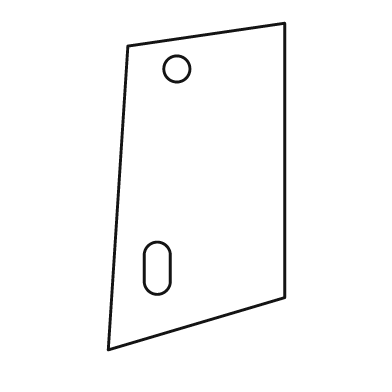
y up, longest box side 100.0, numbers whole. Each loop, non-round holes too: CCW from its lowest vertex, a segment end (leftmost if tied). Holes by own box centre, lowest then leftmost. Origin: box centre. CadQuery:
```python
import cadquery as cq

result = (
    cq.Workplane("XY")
    .moveTo(-27.0, -50.0)
    .lineTo(27.0, -34.0)
    .lineTo(27.0, 50.0)
    .lineTo(-21.0, 43.0)
    .close()
    .moveTo(-16.0, -29.0)
    .threePointArc((-12.0, -33.0), (-8.0, -29.0))
    .lineTo(-8.0, -21.0)
    .threePointArc((-12.0, -17.0), (-16.0, -21.0))
    .close()
    .moveTo(-6.0, 36.0)
    .circle(4.0)
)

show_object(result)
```